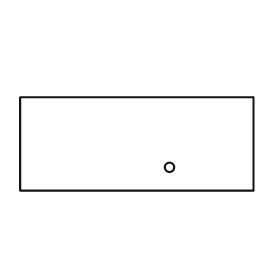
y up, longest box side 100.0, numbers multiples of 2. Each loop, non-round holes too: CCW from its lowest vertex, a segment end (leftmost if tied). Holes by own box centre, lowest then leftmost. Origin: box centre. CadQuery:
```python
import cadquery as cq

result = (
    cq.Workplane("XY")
    .moveTo(-50.0, -20.0)
    .lineTo(50.0, -20.0)
    .lineTo(50.0, 20.0)
    .lineTo(-50.0, 20.0)
    .close()
    .moveTo(14.0, -10.0)
    .circle(2.0)
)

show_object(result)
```